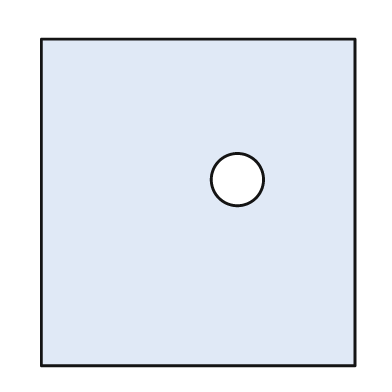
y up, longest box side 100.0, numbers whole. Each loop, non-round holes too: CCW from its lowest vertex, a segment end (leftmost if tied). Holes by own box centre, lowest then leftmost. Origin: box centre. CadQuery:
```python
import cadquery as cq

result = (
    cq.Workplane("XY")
    .moveTo(-48.0, -50.0)
    .lineTo(48.0, -50.0)
    .lineTo(48.0, 50.0)
    .lineTo(-48.0, 50.0)
    .close()
    .moveTo(12.0, 7.0)
    .circle(8.0)
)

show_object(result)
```